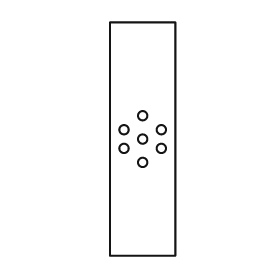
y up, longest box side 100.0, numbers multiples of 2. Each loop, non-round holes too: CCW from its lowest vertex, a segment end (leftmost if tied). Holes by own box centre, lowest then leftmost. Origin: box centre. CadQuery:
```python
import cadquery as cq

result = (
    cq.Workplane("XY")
    .moveTo(-14.0, -50.0)
    .lineTo(14.0, -50.0)
    .lineTo(14.0, 50.0)
    .lineTo(-14.0, 50.0)
    .close()
    .moveTo(0.0, -10.0)
    .circle(2.0)
    .moveTo(-8.0, -4.0)
    .circle(2.0)
    .moveTo(8.0, -4.0)
    .circle(2.0)
    .moveTo(0.0, 0.0)
    .circle(2.0)
    .moveTo(-8.0, 4.0)
    .circle(2.0)
    .moveTo(8.0, 4.0)
    .circle(2.0)
    .moveTo(0.0, 10.0)
    .circle(2.0)
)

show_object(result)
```